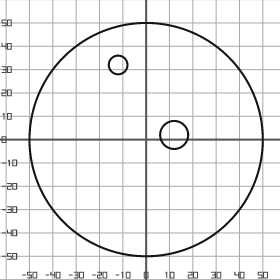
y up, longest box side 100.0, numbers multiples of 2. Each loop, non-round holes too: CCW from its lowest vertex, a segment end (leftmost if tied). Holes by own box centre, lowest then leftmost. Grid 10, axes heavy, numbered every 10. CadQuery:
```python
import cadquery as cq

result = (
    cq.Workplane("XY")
    .moveTo(0.0, 0.0)
    .circle(50.0)
    .moveTo(12.0, 2.0)
    .circle(6.0)
    .moveTo(-12.0, 32.0)
    .circle(4.0)
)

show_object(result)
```